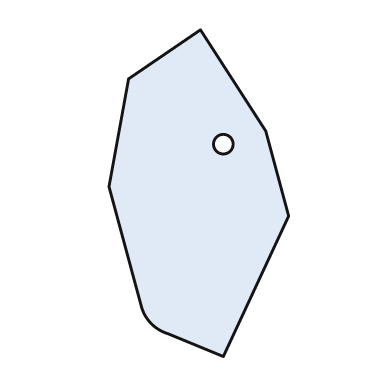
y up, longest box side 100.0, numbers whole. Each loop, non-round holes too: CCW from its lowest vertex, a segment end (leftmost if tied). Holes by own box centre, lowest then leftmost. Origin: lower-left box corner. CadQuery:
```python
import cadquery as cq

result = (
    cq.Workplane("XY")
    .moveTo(35.0, 0.0)
    .lineTo(55.0, 43.0)
    .lineTo(48.0, 69.0)
    .lineTo(28.0, 100.0)
    .lineTo(6.0, 85.0)
    .lineTo(0.0, 52.0)
    .lineTo(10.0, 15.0)
    .threePointArc((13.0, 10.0), (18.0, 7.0))
    .close()
    .moveTo(35.0, 65.0)
    .circle(3.0)
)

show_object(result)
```